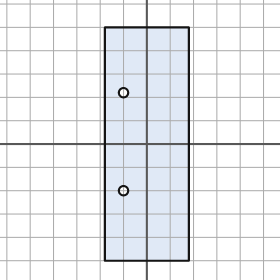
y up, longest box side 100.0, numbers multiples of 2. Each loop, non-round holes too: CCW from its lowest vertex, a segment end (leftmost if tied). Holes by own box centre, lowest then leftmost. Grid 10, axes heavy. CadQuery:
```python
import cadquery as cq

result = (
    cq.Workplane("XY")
    .moveTo(-18.0, -50.0)
    .lineTo(18.0, -50.0)
    .lineTo(18.0, 50.0)
    .lineTo(-18.0, 50.0)
    .close()
    .moveTo(-10.0, -20.0)
    .circle(2.0)
    .moveTo(-10.0, 22.0)
    .circle(2.0)
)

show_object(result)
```